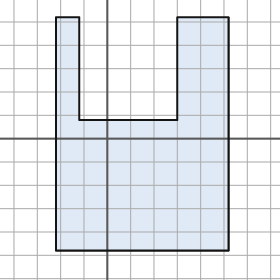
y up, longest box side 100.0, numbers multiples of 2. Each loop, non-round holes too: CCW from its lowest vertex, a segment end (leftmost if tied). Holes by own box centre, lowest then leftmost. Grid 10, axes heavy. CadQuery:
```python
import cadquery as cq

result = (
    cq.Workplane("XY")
    .moveTo(-22.0, -48.0)
    .lineTo(52.0, -48.0)
    .lineTo(52.0, 52.0)
    .lineTo(30.0, 52.0)
    .lineTo(30.0, 8.0)
    .lineTo(-12.0, 8.0)
    .lineTo(-12.0, 52.0)
    .lineTo(-22.0, 52.0)
    .close()
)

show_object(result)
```